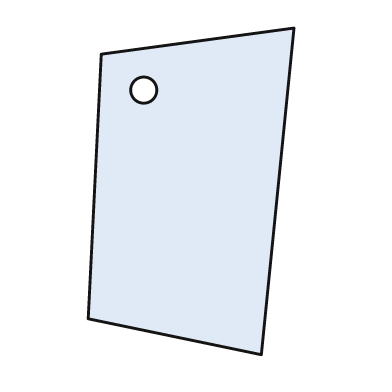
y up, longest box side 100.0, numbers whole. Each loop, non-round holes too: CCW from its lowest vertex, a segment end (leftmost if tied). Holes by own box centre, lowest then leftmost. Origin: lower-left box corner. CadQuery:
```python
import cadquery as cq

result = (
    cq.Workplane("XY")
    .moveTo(53.0, 0.0)
    .lineTo(63.0, 100.0)
    .lineTo(4.0, 92.0)
    .lineTo(0.0, 11.0)
    .close()
    .moveTo(17.0, 81.0)
    .circle(4.0)
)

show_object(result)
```